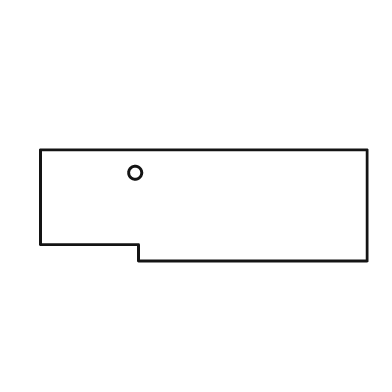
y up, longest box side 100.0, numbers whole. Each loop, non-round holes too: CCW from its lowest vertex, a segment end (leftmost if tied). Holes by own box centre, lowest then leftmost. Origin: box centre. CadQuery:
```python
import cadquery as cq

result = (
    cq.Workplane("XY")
    .moveTo(-20.0, -17.0)
    .lineTo(50.0, -17.0)
    .lineTo(50.0, 17.0)
    .lineTo(-50.0, 17.0)
    .lineTo(-50.0, -12.0)
    .lineTo(-20.0, -12.0)
    .close()
    .moveTo(-21.0, 10.0)
    .circle(2.0)
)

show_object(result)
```